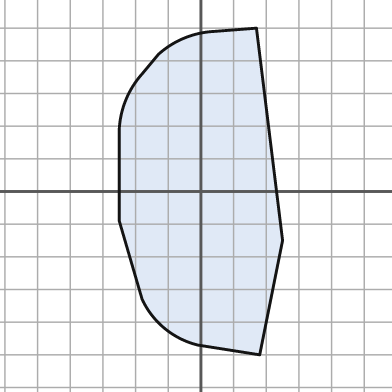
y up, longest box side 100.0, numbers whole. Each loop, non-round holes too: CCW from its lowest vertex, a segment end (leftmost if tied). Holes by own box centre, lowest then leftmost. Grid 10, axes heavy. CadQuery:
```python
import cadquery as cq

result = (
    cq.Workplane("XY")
    .moveTo(18.0, -50.0)
    .lineTo(25.0, -15.0)
    .lineTo(17.0, 50.0)
    .lineTo(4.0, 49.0)
    .threePointArc((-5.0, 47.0), (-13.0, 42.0))
    .lineTo(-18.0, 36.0)
    .threePointArc((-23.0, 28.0), (-25.0, 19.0))
    .lineTo(-25.0, -9.0)
    .lineTo(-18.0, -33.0)
    .threePointArc((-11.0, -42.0), (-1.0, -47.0))
    .close()
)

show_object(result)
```